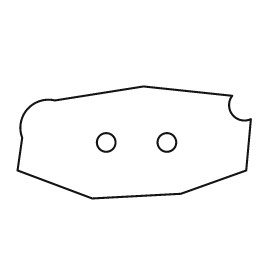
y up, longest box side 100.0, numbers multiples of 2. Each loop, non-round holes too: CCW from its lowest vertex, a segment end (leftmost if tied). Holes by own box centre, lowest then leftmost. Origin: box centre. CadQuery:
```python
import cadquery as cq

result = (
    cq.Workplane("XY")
    .moveTo(-18.0, -24.0)
    .lineTo(20.0, -22.0)
    .lineTo(48.0, -12.0)
    .lineTo(50.0, 10.0)
    .threePointArc((42.0, 12.0), (42.0, 20.0))
    .lineTo(4.0, 24.0)
    .lineTo(-34.0, 18.0)
    .threePointArc((-46.0, 14.0), (-48.0, 2.0))
    .lineTo(-50.0, -12.0)
    .close()
    .moveTo(-12.0, 0.0)
    .circle(4.0)
    .moveTo(14.0, 0.0)
    .circle(4.0)
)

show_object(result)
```